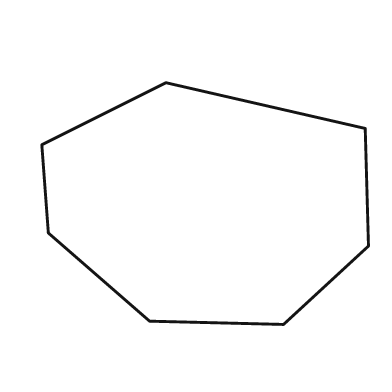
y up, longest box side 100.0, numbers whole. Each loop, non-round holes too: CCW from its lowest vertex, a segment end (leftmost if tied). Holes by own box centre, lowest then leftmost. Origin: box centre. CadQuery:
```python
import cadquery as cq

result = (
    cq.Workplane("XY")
    .moveTo(24.0, -37.0)
    .lineTo(50.0, -13.0)
    .lineTo(49.0, 23.0)
    .lineTo(-12.0, 37.0)
    .lineTo(-50.0, 18.0)
    .lineTo(-48.0, -9.0)
    .lineTo(-17.0, -36.0)
    .close()
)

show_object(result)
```